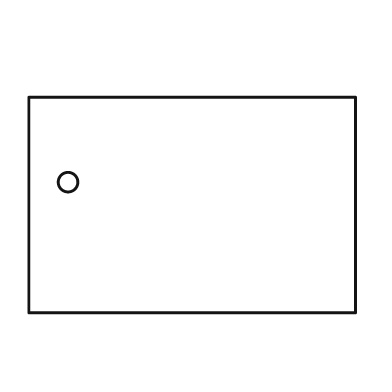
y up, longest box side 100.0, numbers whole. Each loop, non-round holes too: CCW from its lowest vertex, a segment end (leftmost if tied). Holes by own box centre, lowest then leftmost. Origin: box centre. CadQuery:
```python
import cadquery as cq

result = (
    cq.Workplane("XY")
    .moveTo(-50.0, -33.0)
    .lineTo(50.0, -33.0)
    .lineTo(50.0, 33.0)
    .lineTo(-50.0, 33.0)
    .close()
    .moveTo(-38.0, 7.0)
    .circle(3.0)
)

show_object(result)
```